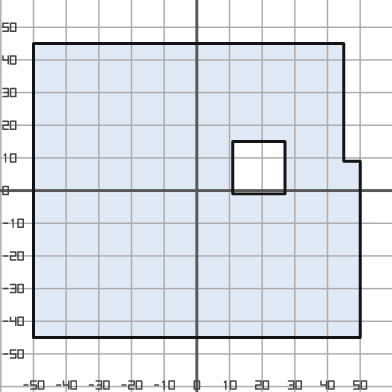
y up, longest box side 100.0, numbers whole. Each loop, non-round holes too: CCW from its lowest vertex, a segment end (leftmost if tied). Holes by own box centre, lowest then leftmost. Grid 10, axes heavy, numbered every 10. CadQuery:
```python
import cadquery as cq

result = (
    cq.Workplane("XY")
    .moveTo(-50.0, -45.0)
    .lineTo(50.0, -45.0)
    .lineTo(50.0, 9.0)
    .lineTo(45.0, 9.0)
    .lineTo(45.0, 45.0)
    .lineTo(-50.0, 45.0)
    .close()
    .moveTo(11.0, -1.0)
    .lineTo(27.0, -1.0)
    .lineTo(27.0, 15.0)
    .lineTo(11.0, 15.0)
    .close()
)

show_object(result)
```